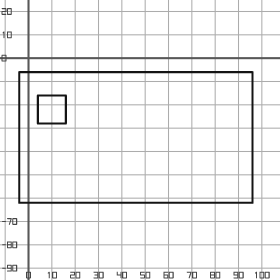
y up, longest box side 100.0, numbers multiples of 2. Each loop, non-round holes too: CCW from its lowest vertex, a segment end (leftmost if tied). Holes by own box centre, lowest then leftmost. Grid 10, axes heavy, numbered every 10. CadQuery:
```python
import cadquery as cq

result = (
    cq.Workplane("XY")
    .moveTo(-4.0, -62.0)
    .lineTo(96.0, -62.0)
    .lineTo(96.0, -6.0)
    .lineTo(-4.0, -6.0)
    .close()
    .moveTo(4.0, -28.0)
    .lineTo(16.0, -28.0)
    .lineTo(16.0, -16.0)
    .lineTo(4.0, -16.0)
    .close()
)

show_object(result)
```